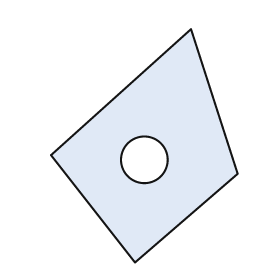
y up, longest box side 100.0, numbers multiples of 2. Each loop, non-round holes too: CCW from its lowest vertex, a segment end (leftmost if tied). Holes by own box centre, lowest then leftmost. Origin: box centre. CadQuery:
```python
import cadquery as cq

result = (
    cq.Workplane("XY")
    .moveTo(-4.0, -50.0)
    .lineTo(40.0, -12.0)
    .lineTo(20.0, 50.0)
    .lineTo(-40.0, -4.0)
    .close()
    .moveTo(0.0, -6.0)
    .circle(10.0)
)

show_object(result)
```